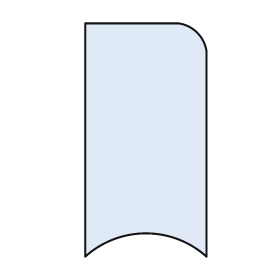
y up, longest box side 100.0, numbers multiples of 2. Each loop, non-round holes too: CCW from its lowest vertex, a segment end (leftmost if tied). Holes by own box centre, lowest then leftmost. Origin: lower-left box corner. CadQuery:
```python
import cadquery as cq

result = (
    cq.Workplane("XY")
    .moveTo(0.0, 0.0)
    .threePointArc((26.0, 10.0), (52.0, 0.0))
    .lineTo(52.0, 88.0)
    .threePointArc((48.0, 96.0), (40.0, 100.0))
    .lineTo(0.0, 100.0)
    .close()
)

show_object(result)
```